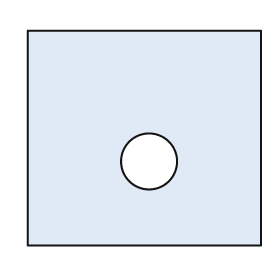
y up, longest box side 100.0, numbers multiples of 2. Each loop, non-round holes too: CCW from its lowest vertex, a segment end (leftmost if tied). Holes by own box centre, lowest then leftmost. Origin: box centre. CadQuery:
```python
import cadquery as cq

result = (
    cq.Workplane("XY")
    .moveTo(-50.0, -46.0)
    .lineTo(50.0, -46.0)
    .lineTo(50.0, 46.0)
    .lineTo(-50.0, 46.0)
    .close()
    .moveTo(2.0, -10.0)
    .circle(12.0)
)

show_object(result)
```